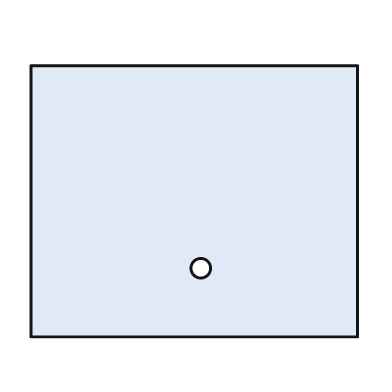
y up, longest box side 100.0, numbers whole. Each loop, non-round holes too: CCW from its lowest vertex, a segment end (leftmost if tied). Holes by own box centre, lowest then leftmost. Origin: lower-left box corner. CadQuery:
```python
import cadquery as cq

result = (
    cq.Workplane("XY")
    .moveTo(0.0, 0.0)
    .lineTo(100.0, 0.0)
    .lineTo(100.0, 83.0)
    .lineTo(0.0, 83.0)
    .close()
    .moveTo(52.0, 21.0)
    .circle(3.0)
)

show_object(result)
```